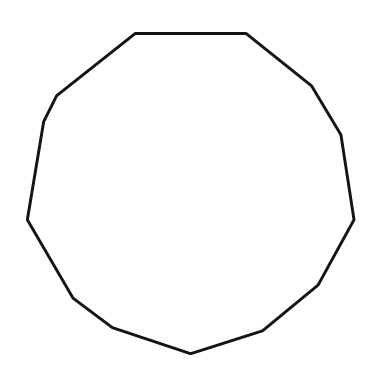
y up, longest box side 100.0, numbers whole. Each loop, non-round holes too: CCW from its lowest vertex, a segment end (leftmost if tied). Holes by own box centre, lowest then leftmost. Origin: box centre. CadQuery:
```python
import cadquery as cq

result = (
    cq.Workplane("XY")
    .moveTo(0.0, -49.0)
    .lineTo(22.0, -42.0)
    .lineTo(39.0, -28.0)
    .lineTo(50.0, -8.0)
    .lineTo(46.0, 18.0)
    .lineTo(37.0, 33.0)
    .lineTo(17.0, 49.0)
    .lineTo(-17.0, 49.0)
    .lineTo(-41.0, 30.0)
    .lineTo(-45.0, 22.0)
    .lineTo(-50.0, -8.0)
    .lineTo(-36.0, -32.0)
    .lineTo(-24.0, -41.0)
    .close()
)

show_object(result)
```